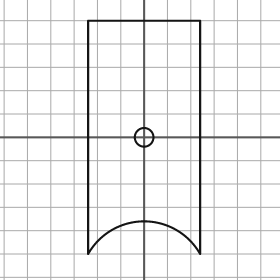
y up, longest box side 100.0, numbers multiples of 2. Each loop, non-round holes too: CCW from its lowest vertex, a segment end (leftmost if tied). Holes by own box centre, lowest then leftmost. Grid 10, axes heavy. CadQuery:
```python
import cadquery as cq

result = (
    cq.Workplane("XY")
    .moveTo(-24.0, -50.0)
    .threePointArc((0.0, -36.0), (24.0, -50.0))
    .lineTo(24.0, 50.0)
    .lineTo(-24.0, 50.0)
    .close()
    .moveTo(0.0, 0.0)
    .circle(4.0)
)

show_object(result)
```